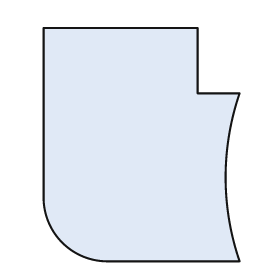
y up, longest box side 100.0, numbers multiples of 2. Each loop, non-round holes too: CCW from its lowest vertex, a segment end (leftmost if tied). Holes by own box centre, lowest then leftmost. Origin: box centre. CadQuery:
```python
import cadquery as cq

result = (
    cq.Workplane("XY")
    .moveTo(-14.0, -50.0)
    .lineTo(42.0, -50.0)
    .threePointArc((36.0, -14.0), (42.0, 22.0))
    .lineTo(24.0, 22.0)
    .lineTo(24.0, 50.0)
    .lineTo(-42.0, 50.0)
    .lineTo(-42.0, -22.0)
    .threePointArc((-34.0, -42.0), (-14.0, -50.0))
    .close()
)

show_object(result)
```